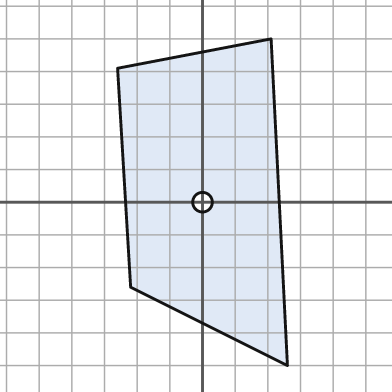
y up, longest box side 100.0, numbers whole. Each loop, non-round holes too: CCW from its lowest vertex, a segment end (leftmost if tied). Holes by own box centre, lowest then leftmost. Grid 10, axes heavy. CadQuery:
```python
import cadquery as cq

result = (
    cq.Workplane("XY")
    .moveTo(26.0, -50.0)
    .lineTo(21.0, 50.0)
    .lineTo(-26.0, 41.0)
    .lineTo(-22.0, -26.0)
    .close()
    .moveTo(0.0, 0.0)
    .circle(3.0)
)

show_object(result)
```